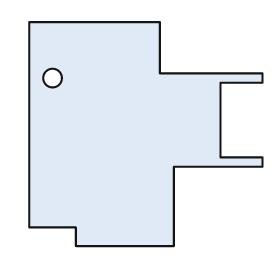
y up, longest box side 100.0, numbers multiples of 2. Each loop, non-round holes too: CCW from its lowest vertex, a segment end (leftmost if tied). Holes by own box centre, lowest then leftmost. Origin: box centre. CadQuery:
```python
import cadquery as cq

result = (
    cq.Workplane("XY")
    .moveTo(-30.0, -48.0)
    .lineTo(12.0, -48.0)
    .lineTo(12.0, -14.0)
    .lineTo(50.0, -14.0)
    .lineTo(50.0, -10.0)
    .lineTo(32.0, -10.0)
    .lineTo(32.0, 22.0)
    .lineTo(50.0, 22.0)
    .lineTo(50.0, 26.0)
    .lineTo(6.0, 26.0)
    .lineTo(6.0, 48.0)
    .lineTo(-50.0, 48.0)
    .lineTo(-50.0, -40.0)
    .lineTo(-30.0, -40.0)
    .close()
    .moveTo(-40.0, 24.0)
    .circle(4.0)
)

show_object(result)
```